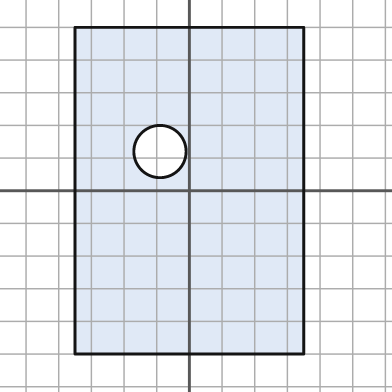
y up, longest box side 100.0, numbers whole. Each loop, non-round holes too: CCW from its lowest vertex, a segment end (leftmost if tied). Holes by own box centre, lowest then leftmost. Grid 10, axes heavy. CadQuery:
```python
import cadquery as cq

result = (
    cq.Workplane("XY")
    .moveTo(-35.0, -50.0)
    .lineTo(35.0, -50.0)
    .lineTo(35.0, 50.0)
    .lineTo(-35.0, 50.0)
    .close()
    .moveTo(-9.0, 12.0)
    .circle(8.0)
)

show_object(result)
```